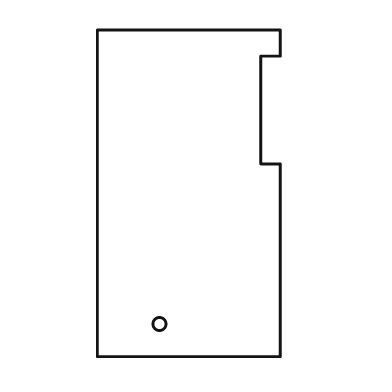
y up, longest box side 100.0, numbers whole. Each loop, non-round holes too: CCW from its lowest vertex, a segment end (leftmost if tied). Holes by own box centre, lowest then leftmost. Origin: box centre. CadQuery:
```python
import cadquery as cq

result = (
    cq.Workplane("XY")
    .moveTo(-28.0, -50.0)
    .lineTo(28.0, -50.0)
    .lineTo(28.0, 9.0)
    .lineTo(22.0, 9.0)
    .lineTo(22.0, 42.0)
    .lineTo(28.0, 42.0)
    .lineTo(28.0, 50.0)
    .lineTo(-28.0, 50.0)
    .close()
    .moveTo(-9.0, -40.0)
    .circle(2.0)
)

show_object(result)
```